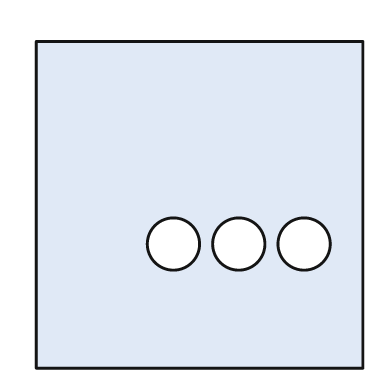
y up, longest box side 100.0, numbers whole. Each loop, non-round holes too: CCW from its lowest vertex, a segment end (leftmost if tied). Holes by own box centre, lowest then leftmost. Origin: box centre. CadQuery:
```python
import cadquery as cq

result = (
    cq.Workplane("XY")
    .moveTo(-50.0, -50.0)
    .lineTo(50.0, -50.0)
    .lineTo(50.0, 50.0)
    .lineTo(-50.0, 50.0)
    .close()
    .moveTo(-8.0, -12.0)
    .circle(8.0)
    .moveTo(12.0, -12.0)
    .circle(8.0)
    .moveTo(32.0, -12.0)
    .circle(8.0)
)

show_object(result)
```